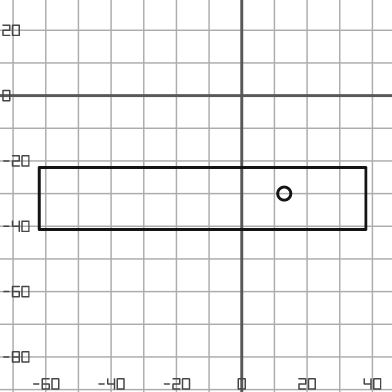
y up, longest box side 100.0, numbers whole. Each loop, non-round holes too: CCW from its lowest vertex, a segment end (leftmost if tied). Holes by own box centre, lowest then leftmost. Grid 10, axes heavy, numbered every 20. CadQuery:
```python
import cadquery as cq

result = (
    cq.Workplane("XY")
    .moveTo(-62.0, -41.0)
    .lineTo(38.0, -41.0)
    .lineTo(38.0, -22.0)
    .lineTo(-62.0, -22.0)
    .close()
    .moveTo(13.0, -30.0)
    .circle(2.0)
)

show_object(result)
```